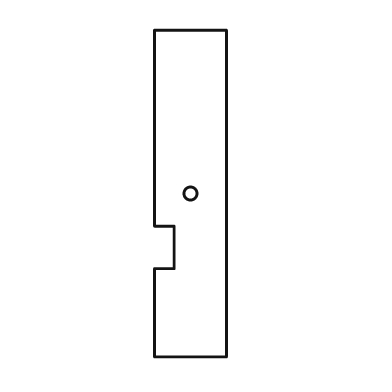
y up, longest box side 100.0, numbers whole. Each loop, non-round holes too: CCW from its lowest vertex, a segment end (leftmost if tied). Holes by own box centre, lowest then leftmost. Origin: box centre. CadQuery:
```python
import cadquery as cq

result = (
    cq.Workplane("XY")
    .moveTo(-11.0, -50.0)
    .lineTo(11.0, -50.0)
    .lineTo(11.0, 50.0)
    .lineTo(-11.0, 50.0)
    .lineTo(-11.0, -10.0)
    .lineTo(-5.0, -10.0)
    .lineTo(-5.0, -23.0)
    .lineTo(-11.0, -23.0)
    .close()
    .moveTo(0.0, 0.0)
    .circle(2.0)
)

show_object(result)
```